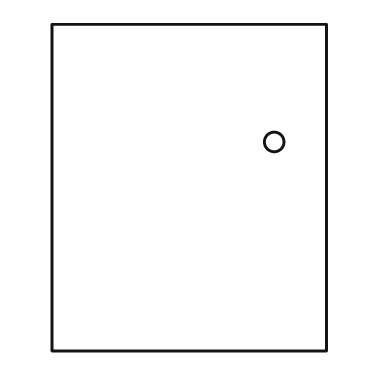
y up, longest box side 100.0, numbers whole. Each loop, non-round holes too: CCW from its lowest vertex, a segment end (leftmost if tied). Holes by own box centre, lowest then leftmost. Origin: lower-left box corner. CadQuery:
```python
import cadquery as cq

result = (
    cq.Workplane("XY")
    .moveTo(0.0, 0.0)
    .lineTo(84.0, 0.0)
    .lineTo(84.0, 100.0)
    .lineTo(0.0, 100.0)
    .close()
    .moveTo(68.0, 64.0)
    .circle(3.0)
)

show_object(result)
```